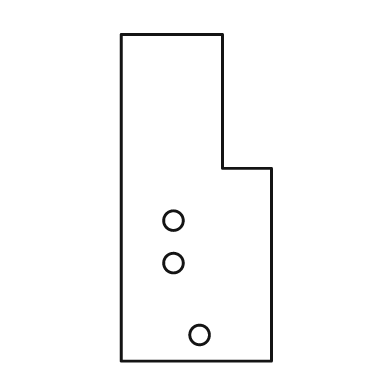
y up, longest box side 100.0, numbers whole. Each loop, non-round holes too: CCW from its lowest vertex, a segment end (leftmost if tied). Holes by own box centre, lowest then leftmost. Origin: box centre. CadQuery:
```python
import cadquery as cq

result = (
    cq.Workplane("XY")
    .moveTo(-23.0, -50.0)
    .lineTo(23.0, -50.0)
    .lineTo(23.0, 9.0)
    .lineTo(8.0, 9.0)
    .lineTo(8.0, 50.0)
    .lineTo(-23.0, 50.0)
    .close()
    .moveTo(1.0, -42.0)
    .circle(3.0)
    .moveTo(-7.0, -20.0)
    .circle(3.0)
    .moveTo(-7.0, -7.0)
    .circle(3.0)
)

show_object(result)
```